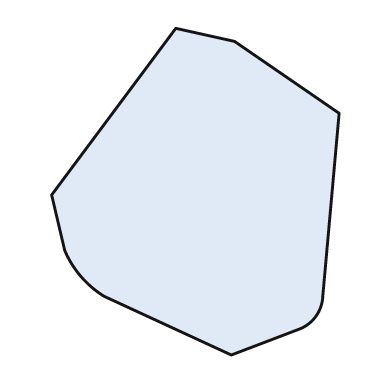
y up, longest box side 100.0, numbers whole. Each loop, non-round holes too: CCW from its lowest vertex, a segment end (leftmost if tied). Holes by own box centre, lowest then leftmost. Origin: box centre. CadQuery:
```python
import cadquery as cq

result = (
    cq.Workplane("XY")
    .moveTo(11.0, -50.0)
    .lineTo(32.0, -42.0)
    .threePointArc((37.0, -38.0), (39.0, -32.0))
    .lineTo(44.0, 24.0)
    .lineTo(12.0, 46.0)
    .lineTo(-6.0, 50.0)
    .lineTo(-44.0, -1.0)
    .lineTo(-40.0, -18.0)
    .threePointArc((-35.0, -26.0), (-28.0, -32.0))
    .close()
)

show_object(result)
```